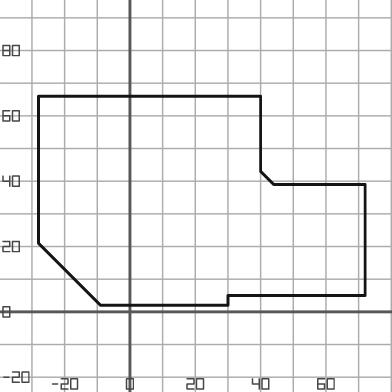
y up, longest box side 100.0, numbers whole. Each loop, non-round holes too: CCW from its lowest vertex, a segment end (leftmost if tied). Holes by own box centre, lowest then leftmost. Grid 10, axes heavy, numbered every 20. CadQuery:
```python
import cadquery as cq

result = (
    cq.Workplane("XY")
    .moveTo(-9.0, 2.0)
    .lineTo(30.0, 2.0)
    .lineTo(30.0, 5.0)
    .lineTo(72.0, 5.0)
    .lineTo(72.0, 39.0)
    .lineTo(44.0, 39.0)
    .lineTo(40.0, 43.0)
    .lineTo(40.0, 66.0)
    .lineTo(-28.0, 66.0)
    .lineTo(-28.0, 21.0)
    .close()
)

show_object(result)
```